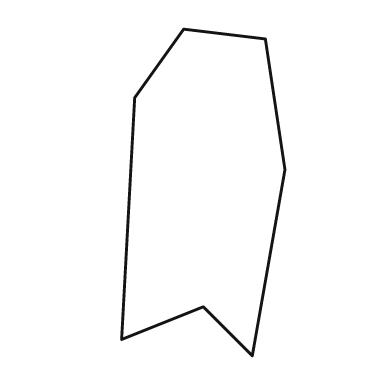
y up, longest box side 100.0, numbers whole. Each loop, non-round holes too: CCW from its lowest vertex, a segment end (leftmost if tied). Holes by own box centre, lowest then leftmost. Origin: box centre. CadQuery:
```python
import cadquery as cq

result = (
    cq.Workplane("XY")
    .moveTo(15.0, -50.0)
    .lineTo(25.0, 7.0)
    .lineTo(19.0, 47.0)
    .lineTo(-6.0, 50.0)
    .lineTo(-21.0, 29.0)
    .lineTo(-25.0, -45.0)
    .lineTo(0.0, -35.0)
    .close()
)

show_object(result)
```